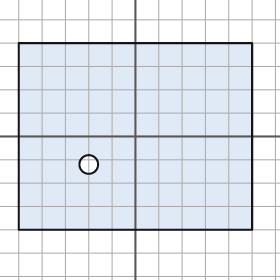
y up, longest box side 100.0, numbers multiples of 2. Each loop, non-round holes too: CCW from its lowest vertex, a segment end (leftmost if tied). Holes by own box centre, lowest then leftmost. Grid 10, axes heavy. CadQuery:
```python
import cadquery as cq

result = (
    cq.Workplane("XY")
    .moveTo(-50.0, -40.0)
    .lineTo(50.0, -40.0)
    .lineTo(50.0, 40.0)
    .lineTo(-50.0, 40.0)
    .close()
    .moveTo(-20.0, -12.0)
    .circle(4.0)
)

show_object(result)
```